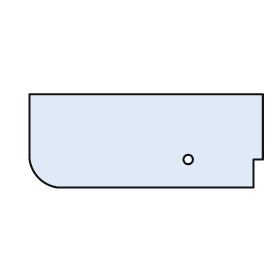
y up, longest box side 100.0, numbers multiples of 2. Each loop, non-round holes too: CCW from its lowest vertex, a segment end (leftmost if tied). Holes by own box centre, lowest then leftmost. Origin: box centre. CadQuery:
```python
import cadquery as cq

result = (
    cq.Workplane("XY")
    .moveTo(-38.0, -20.0)
    .lineTo(46.0, -20.0)
    .lineTo(46.0, -8.0)
    .lineTo(50.0, -8.0)
    .lineTo(50.0, 20.0)
    .lineTo(-50.0, 20.0)
    .lineTo(-50.0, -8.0)
    .threePointArc((-46.0, -16.0), (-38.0, -20.0))
    .close()
    .moveTo(18.0, -8.0)
    .circle(2.0)
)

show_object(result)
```